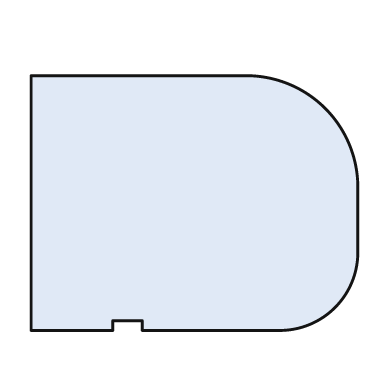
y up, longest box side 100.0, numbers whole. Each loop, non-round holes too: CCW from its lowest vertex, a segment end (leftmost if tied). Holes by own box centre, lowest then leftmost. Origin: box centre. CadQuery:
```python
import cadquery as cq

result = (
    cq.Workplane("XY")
    .moveTo(-50.0, -39.0)
    .lineTo(-25.0, -39.0)
    .lineTo(-25.0, -36.0)
    .lineTo(-16.0, -36.0)
    .lineTo(-16.0, -39.0)
    .lineTo(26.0, -39.0)
    .threePointArc((43.0, -32.0), (50.0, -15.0))
    .lineTo(50.0, 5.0)
    .threePointArc((40.0, 29.0), (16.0, 39.0))
    .lineTo(-50.0, 39.0)
    .close()
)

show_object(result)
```